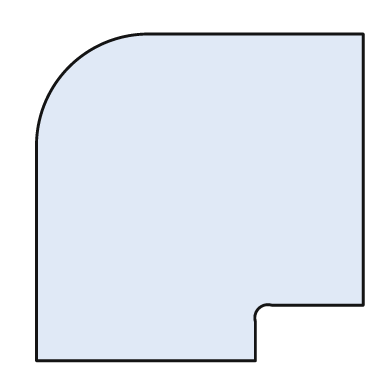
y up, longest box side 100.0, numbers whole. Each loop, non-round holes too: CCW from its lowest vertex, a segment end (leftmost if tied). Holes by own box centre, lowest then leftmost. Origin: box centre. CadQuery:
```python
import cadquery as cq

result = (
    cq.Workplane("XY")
    .moveTo(-50.0, -50.0)
    .lineTo(17.0, -50.0)
    .lineTo(17.0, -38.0)
    .threePointArc((18.0, -34.0), (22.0, -33.0))
    .lineTo(50.0, -33.0)
    .lineTo(50.0, 50.0)
    .lineTo(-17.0, 50.0)
    .threePointArc((-40.0, 40.0), (-50.0, 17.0))
    .close()
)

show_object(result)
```